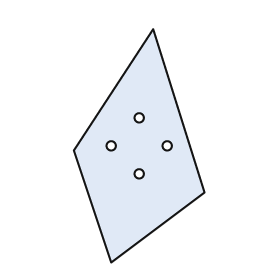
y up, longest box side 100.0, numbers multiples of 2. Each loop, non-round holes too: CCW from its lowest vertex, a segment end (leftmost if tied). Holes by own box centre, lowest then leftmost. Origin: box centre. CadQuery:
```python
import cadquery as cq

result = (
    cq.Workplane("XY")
    .moveTo(-12.0, -50.0)
    .lineTo(28.0, -20.0)
    .lineTo(6.0, 50.0)
    .lineTo(-28.0, -2.0)
    .close()
    .moveTo(0.0, -12.0)
    .circle(2.0)
    .moveTo(-12.0, 0.0)
    .circle(2.0)
    .moveTo(12.0, 0.0)
    .circle(2.0)
    .moveTo(0.0, 12.0)
    .circle(2.0)
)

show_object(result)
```